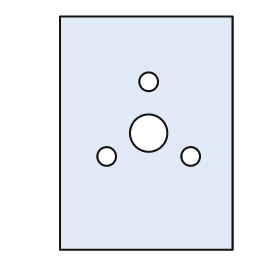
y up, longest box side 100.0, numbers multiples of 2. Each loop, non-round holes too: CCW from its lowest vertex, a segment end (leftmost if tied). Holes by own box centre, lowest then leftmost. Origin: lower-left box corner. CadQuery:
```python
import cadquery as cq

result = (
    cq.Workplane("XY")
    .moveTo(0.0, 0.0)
    .lineTo(74.0, 0.0)
    .lineTo(74.0, 100.0)
    .lineTo(0.0, 100.0)
    .close()
    .moveTo(20.0, 40.0)
    .circle(4.0)
    .moveTo(56.0, 40.0)
    .circle(4.0)
    .moveTo(38.0, 50.0)
    .circle(8.0)
    .moveTo(38.0, 72.0)
    .circle(4.0)
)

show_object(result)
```